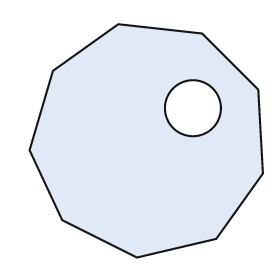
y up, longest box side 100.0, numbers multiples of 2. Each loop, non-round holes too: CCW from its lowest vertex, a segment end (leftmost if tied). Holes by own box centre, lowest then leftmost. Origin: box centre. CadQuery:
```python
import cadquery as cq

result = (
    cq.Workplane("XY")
    .moveTo(-4.0, -50.0)
    .lineTo(30.0, -42.0)
    .lineTo(50.0, -14.0)
    .lineTo(48.0, 22.0)
    .lineTo(24.0, 46.0)
    .lineTo(-12.0, 50.0)
    .lineTo(-40.0, 30.0)
    .lineTo(-50.0, -4.0)
    .lineTo(-36.0, -34.0)
    .close()
    .moveTo(20.0, 14.0)
    .circle(12.0)
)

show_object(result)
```